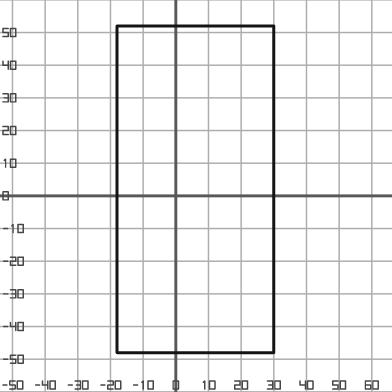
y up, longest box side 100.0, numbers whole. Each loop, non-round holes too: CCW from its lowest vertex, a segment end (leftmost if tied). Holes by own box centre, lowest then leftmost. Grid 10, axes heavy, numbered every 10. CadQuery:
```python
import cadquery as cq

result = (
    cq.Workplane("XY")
    .moveTo(-18.0, -48.0)
    .lineTo(30.0, -48.0)
    .lineTo(30.0, 52.0)
    .lineTo(-18.0, 52.0)
    .close()
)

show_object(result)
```